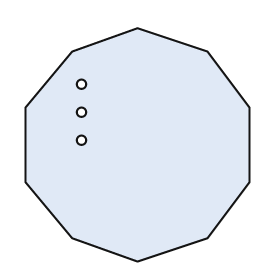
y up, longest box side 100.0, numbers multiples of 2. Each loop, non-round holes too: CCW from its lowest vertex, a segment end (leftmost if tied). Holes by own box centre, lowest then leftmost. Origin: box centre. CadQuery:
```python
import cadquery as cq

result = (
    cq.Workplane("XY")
    .moveTo(0.0, -50.0)
    .lineTo(30.0, -40.0)
    .lineTo(48.0, -16.0)
    .lineTo(48.0, 16.0)
    .lineTo(30.0, 40.0)
    .lineTo(0.0, 50.0)
    .lineTo(-28.0, 40.0)
    .lineTo(-48.0, 16.0)
    .lineTo(-48.0, -16.0)
    .lineTo(-28.0, -40.0)
    .close()
    .moveTo(-24.0, 2.0)
    .circle(2.0)
    .moveTo(-24.0, 14.0)
    .circle(2.0)
    .moveTo(-24.0, 26.0)
    .circle(2.0)
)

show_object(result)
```